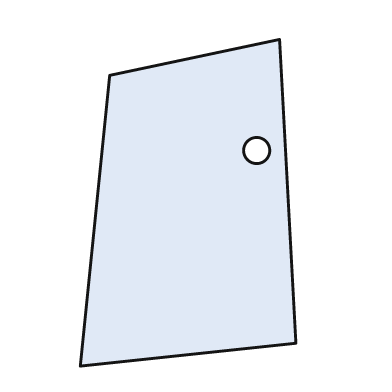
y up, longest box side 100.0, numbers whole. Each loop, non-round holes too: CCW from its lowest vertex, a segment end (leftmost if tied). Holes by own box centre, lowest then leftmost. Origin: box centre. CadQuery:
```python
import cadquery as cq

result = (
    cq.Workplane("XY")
    .moveTo(-33.0, -50.0)
    .lineTo(33.0, -43.0)
    .lineTo(28.0, 50.0)
    .lineTo(-24.0, 39.0)
    .close()
    .moveTo(21.0, 16.0)
    .circle(4.0)
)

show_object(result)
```